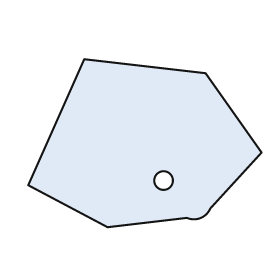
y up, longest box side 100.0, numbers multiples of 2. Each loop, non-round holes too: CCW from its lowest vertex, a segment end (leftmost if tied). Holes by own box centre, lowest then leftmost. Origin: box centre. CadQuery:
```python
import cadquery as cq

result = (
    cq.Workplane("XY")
    .moveTo(-16.0, -36.0)
    .lineTo(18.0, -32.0)
    .threePointArc((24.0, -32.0), (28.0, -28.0))
    .lineTo(50.0, -4.0)
    .lineTo(26.0, 30.0)
    .lineTo(-26.0, 36.0)
    .lineTo(-50.0, -18.0)
    .close()
    .moveTo(8.0, -16.0)
    .circle(4.0)
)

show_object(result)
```